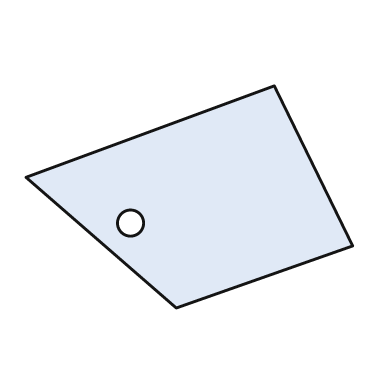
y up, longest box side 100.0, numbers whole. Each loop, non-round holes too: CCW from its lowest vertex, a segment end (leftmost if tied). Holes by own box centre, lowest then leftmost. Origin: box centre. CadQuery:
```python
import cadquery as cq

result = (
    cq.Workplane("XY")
    .moveTo(-4.0, -34.0)
    .lineTo(50.0, -15.0)
    .lineTo(26.0, 34.0)
    .lineTo(-50.0, 6.0)
    .close()
    .moveTo(-18.0, -8.0)
    .circle(4.0)
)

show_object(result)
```